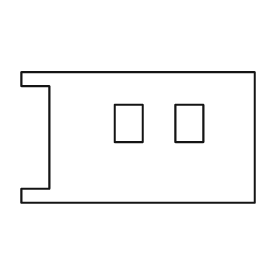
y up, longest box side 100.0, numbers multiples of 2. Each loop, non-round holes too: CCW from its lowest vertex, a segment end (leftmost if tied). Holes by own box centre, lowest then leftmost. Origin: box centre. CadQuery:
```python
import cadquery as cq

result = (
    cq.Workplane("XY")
    .moveTo(-50.0, -28.0)
    .lineTo(50.0, -28.0)
    .lineTo(50.0, 28.0)
    .lineTo(-50.0, 28.0)
    .lineTo(-50.0, 22.0)
    .lineTo(-38.0, 22.0)
    .lineTo(-38.0, -22.0)
    .lineTo(-50.0, -22.0)
    .close()
    .moveTo(-10.0, -2.0)
    .lineTo(2.0, -2.0)
    .lineTo(2.0, 14.0)
    .lineTo(-10.0, 14.0)
    .close()
    .moveTo(16.0, -2.0)
    .lineTo(28.0, -2.0)
    .lineTo(28.0, 14.0)
    .lineTo(16.0, 14.0)
    .close()
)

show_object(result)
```